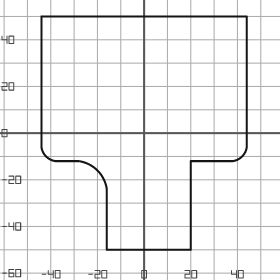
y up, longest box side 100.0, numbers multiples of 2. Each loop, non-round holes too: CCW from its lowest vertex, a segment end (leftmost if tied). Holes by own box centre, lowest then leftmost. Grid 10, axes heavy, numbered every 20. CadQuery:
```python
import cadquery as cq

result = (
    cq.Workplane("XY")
    .moveTo(-16.0, -50.0)
    .lineTo(20.0, -50.0)
    .lineTo(20.0, -12.0)
    .lineTo(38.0, -12.0)
    .threePointArc((42.0, -10.0), (44.0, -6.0))
    .lineTo(44.0, 50.0)
    .lineTo(-44.0, 50.0)
    .lineTo(-44.0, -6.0)
    .threePointArc((-42.0, -10.0), (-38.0, -12.0))
    .lineTo(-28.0, -12.0)
    .threePointArc((-20.0, -16.0), (-16.0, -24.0))
    .close()
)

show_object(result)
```